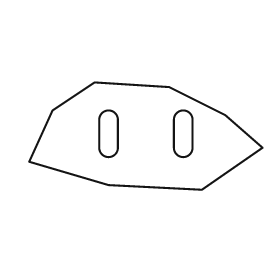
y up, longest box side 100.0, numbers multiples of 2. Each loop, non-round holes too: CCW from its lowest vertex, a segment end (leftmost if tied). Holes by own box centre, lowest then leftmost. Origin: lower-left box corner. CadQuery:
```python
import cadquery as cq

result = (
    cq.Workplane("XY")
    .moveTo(74.0, 0.0)
    .lineTo(100.0, 18.0)
    .lineTo(84.0, 32.0)
    .lineTo(60.0, 44.0)
    .lineTo(28.0, 46.0)
    .lineTo(10.0, 34.0)
    .lineTo(0.0, 12.0)
    .lineTo(34.0, 2.0)
    .close()
    .moveTo(30.0, 18.0)
    .threePointArc((34.0, 14.0), (38.0, 18.0))
    .lineTo(38.0, 30.0)
    .threePointArc((34.0, 34.0), (30.0, 30.0))
    .close()
    .moveTo(62.0, 18.0)
    .threePointArc((66.0, 14.0), (70.0, 18.0))
    .lineTo(70.0, 30.0)
    .threePointArc((66.0, 34.0), (62.0, 30.0))
    .close()
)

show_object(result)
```